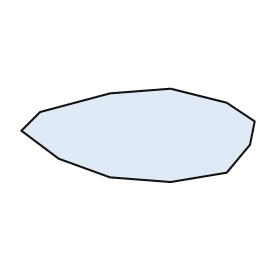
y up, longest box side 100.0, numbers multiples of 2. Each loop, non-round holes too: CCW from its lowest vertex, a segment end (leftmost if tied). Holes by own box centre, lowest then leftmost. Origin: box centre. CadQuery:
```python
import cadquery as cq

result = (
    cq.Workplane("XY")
    .moveTo(14.0, -20.0)
    .lineTo(38.0, -16.0)
    .lineTo(48.0, -4.0)
    .lineTo(50.0, 6.0)
    .lineTo(38.0, 14.0)
    .lineTo(14.0, 20.0)
    .lineTo(-12.0, 18.0)
    .lineTo(-42.0, 10.0)
    .lineTo(-50.0, 2.0)
    .lineTo(-34.0, -10.0)
    .lineTo(-12.0, -18.0)
    .close()
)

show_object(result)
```